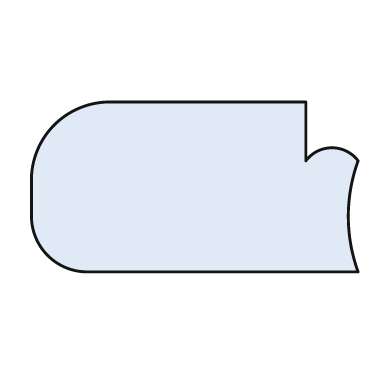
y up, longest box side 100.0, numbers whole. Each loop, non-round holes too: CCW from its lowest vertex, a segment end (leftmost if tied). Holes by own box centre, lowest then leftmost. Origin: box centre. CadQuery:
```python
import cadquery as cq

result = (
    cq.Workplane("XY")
    .moveTo(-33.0, -26.0)
    .lineTo(50.0, -26.0)
    .threePointArc((47.0, -9.0), (50.0, 8.0))
    .threePointArc((42.0, 12.0), (34.0, 8.0))
    .lineTo(34.0, 26.0)
    .lineTo(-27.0, 26.0)
    .threePointArc((-43.0, 19.0), (-50.0, 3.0))
    .lineTo(-50.0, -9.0)
    .threePointArc((-45.0, -21.0), (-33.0, -26.0))
    .close()
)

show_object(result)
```